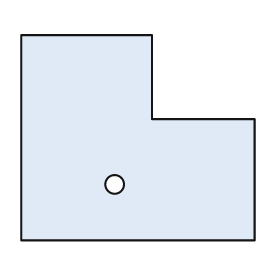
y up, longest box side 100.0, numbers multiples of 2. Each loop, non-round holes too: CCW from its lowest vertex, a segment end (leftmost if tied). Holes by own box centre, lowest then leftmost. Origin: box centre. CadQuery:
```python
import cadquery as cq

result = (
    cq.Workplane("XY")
    .moveTo(-50.0, -44.0)
    .lineTo(50.0, -44.0)
    .lineTo(50.0, 8.0)
    .lineTo(6.0, 8.0)
    .lineTo(6.0, 44.0)
    .lineTo(-50.0, 44.0)
    .close()
    .moveTo(-10.0, -20.0)
    .circle(4.0)
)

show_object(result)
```